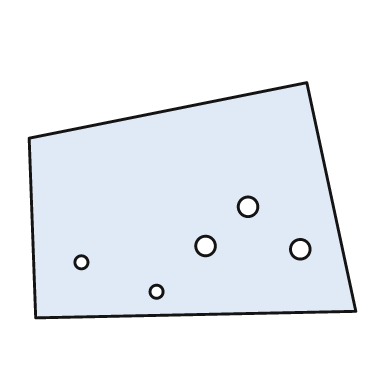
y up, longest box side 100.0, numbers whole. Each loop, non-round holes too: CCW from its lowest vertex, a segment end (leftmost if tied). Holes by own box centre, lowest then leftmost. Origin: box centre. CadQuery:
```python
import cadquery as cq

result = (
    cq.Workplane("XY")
    .moveTo(-48.0, -36.0)
    .lineTo(50.0, -34.0)
    .lineTo(35.0, 36.0)
    .lineTo(-50.0, 19.0)
    .close()
    .moveTo(-11.0, -28.0)
    .circle(2.0)
    .moveTo(-34.0, -19.0)
    .circle(2.0)
    .moveTo(33.0, -15.0)
    .circle(3.0)
    .moveTo(4.0, -14.0)
    .circle(3.0)
    .moveTo(17.0, -2.0)
    .circle(3.0)
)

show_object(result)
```